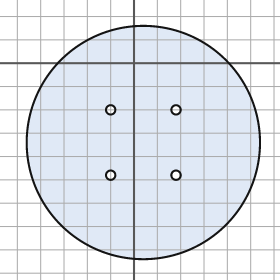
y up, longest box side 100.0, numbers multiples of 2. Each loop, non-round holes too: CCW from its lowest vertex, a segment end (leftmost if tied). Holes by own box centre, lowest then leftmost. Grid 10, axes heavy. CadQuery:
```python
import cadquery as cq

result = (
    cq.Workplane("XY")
    .moveTo(4.0, -34.0)
    .circle(50.0)
    .moveTo(-10.0, -48.0)
    .circle(2.0)
    .moveTo(18.0, -48.0)
    .circle(2.0)
    .moveTo(-10.0, -20.0)
    .circle(2.0)
    .moveTo(18.0, -20.0)
    .circle(2.0)
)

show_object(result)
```